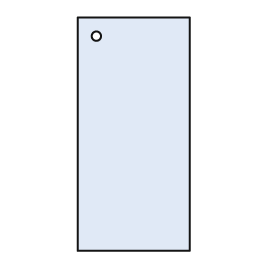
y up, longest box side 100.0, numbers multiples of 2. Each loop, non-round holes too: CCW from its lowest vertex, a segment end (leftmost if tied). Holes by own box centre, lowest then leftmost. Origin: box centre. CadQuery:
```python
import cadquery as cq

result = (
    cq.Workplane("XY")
    .moveTo(-24.0, -50.0)
    .lineTo(24.0, -50.0)
    .lineTo(24.0, 50.0)
    .lineTo(-24.0, 50.0)
    .close()
    .moveTo(-16.0, 42.0)
    .circle(2.0)
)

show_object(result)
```